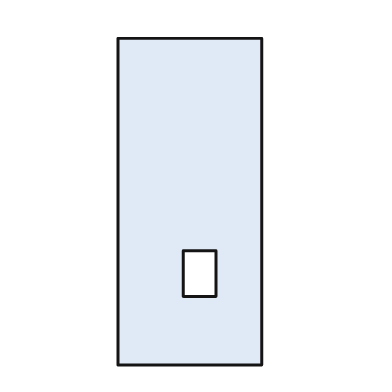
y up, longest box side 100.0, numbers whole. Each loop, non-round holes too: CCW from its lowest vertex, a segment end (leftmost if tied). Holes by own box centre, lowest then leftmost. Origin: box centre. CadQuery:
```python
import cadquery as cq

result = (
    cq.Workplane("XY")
    .moveTo(-22.0, -50.0)
    .lineTo(22.0, -50.0)
    .lineTo(22.0, 50.0)
    .lineTo(-22.0, 50.0)
    .close()
    .moveTo(-2.0, -29.0)
    .lineTo(8.0, -29.0)
    .lineTo(8.0, -15.0)
    .lineTo(-2.0, -15.0)
    .close()
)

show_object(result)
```